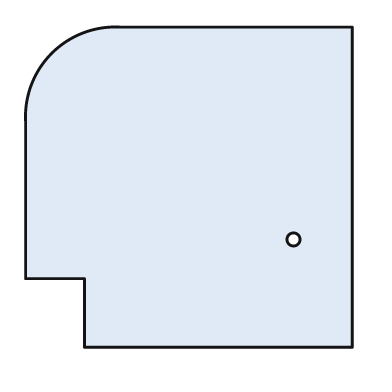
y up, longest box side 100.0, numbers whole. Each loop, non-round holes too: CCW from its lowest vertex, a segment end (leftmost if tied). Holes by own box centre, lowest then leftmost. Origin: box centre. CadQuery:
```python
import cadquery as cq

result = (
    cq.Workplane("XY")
    .moveTo(-32.0, -49.0)
    .lineTo(50.0, -49.0)
    .lineTo(50.0, 49.0)
    .lineTo(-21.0, 49.0)
    .threePointArc((-42.0, 41.0), (-50.0, 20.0))
    .lineTo(-50.0, -28.0)
    .lineTo(-32.0, -28.0)
    .close()
    .moveTo(32.0, -16.0)
    .circle(2.0)
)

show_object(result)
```